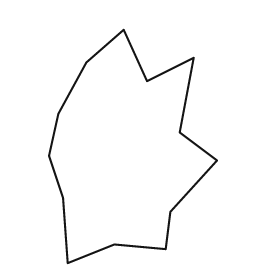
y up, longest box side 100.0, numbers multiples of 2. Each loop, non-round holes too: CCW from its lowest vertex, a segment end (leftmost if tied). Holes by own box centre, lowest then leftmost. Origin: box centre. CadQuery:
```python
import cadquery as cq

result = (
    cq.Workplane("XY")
    .moveTo(-28.0, -50.0)
    .lineTo(-8.0, -42.0)
    .lineTo(14.0, -44.0)
    .lineTo(16.0, -28.0)
    .lineTo(36.0, -6.0)
    .lineTo(20.0, 6.0)
    .lineTo(26.0, 38.0)
    .lineTo(6.0, 28.0)
    .lineTo(-4.0, 50.0)
    .lineTo(-20.0, 36.0)
    .lineTo(-32.0, 14.0)
    .lineTo(-36.0, -4.0)
    .lineTo(-30.0, -22.0)
    .close()
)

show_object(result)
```